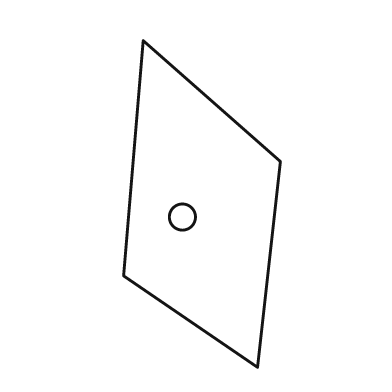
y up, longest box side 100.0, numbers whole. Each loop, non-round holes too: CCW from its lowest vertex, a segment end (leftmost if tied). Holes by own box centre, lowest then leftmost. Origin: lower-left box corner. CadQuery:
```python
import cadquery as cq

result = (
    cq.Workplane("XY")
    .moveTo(41.0, 0.0)
    .lineTo(48.0, 63.0)
    .lineTo(6.0, 100.0)
    .lineTo(0.0, 28.0)
    .close()
    .moveTo(18.0, 46.0)
    .circle(4.0)
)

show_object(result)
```